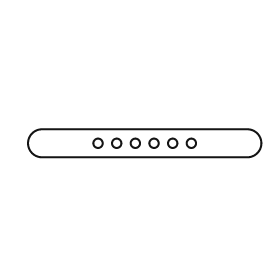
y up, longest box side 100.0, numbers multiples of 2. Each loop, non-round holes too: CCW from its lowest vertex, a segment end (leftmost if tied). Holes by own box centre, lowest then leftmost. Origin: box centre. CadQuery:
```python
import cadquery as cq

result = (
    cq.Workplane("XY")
    .moveTo(-44.0, -6.0)
    .lineTo(44.0, -6.0)
    .threePointArc((50.0, 0.0), (44.0, 6.0))
    .lineTo(-44.0, 6.0)
    .threePointArc((-50.0, 0.0), (-44.0, -6.0))
    .close()
    .moveTo(-20.0, 0.0)
    .circle(2.0)
    .moveTo(-12.0, 0.0)
    .circle(2.0)
    .moveTo(-4.0, 0.0)
    .circle(2.0)
    .moveTo(4.0, 0.0)
    .circle(2.0)
    .moveTo(12.0, 0.0)
    .circle(2.0)
    .moveTo(20.0, 0.0)
    .circle(2.0)
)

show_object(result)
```